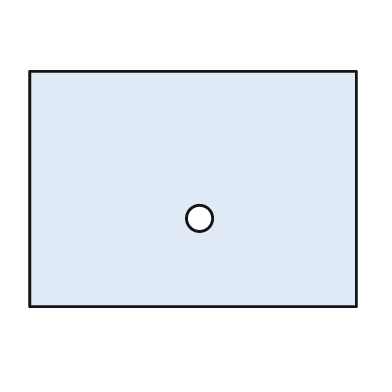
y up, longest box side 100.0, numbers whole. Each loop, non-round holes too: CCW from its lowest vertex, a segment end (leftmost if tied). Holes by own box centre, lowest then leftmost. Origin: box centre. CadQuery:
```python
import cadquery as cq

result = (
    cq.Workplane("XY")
    .moveTo(-50.0, -36.0)
    .lineTo(50.0, -36.0)
    .lineTo(50.0, 36.0)
    .lineTo(-50.0, 36.0)
    .close()
    .moveTo(2.0, -9.0)
    .circle(4.0)
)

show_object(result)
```